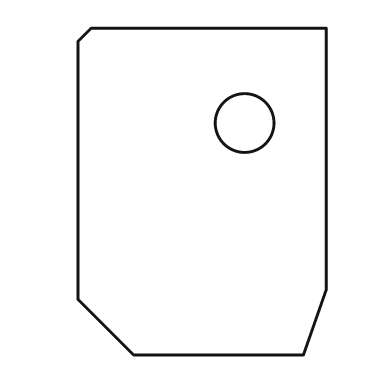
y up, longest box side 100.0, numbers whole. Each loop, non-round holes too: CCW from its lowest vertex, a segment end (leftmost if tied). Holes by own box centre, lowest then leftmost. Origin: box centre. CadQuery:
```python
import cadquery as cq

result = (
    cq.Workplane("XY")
    .moveTo(-21.0, -50.0)
    .lineTo(31.0, -50.0)
    .lineTo(38.0, -30.0)
    .lineTo(38.0, 50.0)
    .lineTo(-34.0, 50.0)
    .lineTo(-38.0, 46.0)
    .lineTo(-38.0, -33.0)
    .close()
    .moveTo(13.0, 21.0)
    .circle(9.0)
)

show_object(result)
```